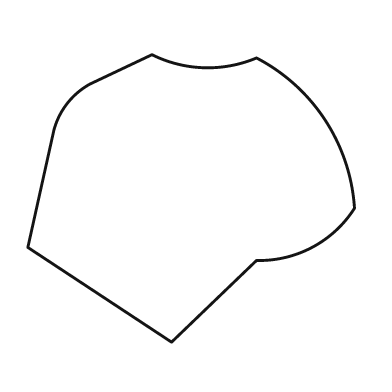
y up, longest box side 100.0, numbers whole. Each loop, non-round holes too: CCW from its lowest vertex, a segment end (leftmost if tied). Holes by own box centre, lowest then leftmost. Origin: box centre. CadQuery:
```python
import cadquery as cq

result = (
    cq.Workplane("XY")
    .moveTo(-6.0, -44.0)
    .lineTo(20.0, -19.0)
    .threePointArc((37.0, -15.0), (50.0, -3.0))
    .threePointArc((41.0, 24.0), (20.0, 43.0))
    .threePointArc((4.0, 40.0), (-12.0, 44.0))
    .lineTo(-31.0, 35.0)
    .threePointArc((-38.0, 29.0), (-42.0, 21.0))
    .lineTo(-50.0, -15.0)
    .close()
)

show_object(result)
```